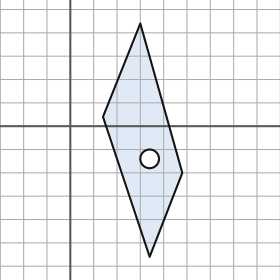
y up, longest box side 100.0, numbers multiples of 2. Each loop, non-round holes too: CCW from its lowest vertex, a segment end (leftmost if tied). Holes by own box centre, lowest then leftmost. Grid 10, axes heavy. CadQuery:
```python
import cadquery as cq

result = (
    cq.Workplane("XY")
    .moveTo(34.0, -56.0)
    .lineTo(48.0, -20.0)
    .lineTo(30.0, 44.0)
    .lineTo(14.0, 4.0)
    .close()
    .moveTo(34.0, -14.0)
    .circle(4.0)
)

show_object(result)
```